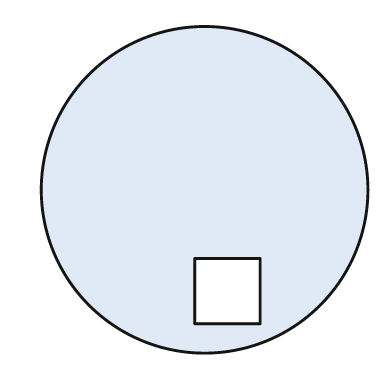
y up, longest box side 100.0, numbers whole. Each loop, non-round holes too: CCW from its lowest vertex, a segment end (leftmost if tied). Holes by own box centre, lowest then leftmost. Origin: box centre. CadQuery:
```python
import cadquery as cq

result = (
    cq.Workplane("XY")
    .moveTo(0.0, 0.0)
    .circle(50.0)
    .moveTo(-3.0, -41.0)
    .lineTo(17.0, -41.0)
    .lineTo(17.0, -21.0)
    .lineTo(-3.0, -21.0)
    .close()
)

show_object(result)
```